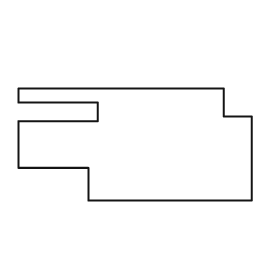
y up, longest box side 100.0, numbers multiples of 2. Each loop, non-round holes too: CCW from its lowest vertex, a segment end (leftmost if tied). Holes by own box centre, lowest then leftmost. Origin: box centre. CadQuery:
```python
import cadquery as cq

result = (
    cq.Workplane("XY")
    .moveTo(-20.0, -24.0)
    .lineTo(50.0, -24.0)
    .lineTo(50.0, 12.0)
    .lineTo(38.0, 12.0)
    .lineTo(38.0, 24.0)
    .lineTo(-50.0, 24.0)
    .lineTo(-50.0, 18.0)
    .lineTo(-16.0, 18.0)
    .lineTo(-16.0, 10.0)
    .lineTo(-50.0, 10.0)
    .lineTo(-50.0, -10.0)
    .lineTo(-20.0, -10.0)
    .close()
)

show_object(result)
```